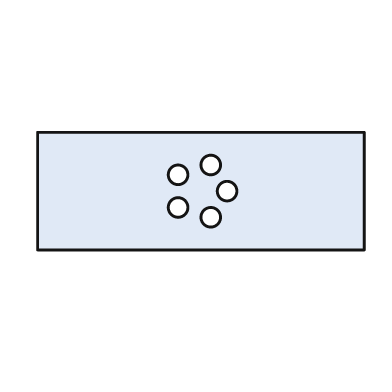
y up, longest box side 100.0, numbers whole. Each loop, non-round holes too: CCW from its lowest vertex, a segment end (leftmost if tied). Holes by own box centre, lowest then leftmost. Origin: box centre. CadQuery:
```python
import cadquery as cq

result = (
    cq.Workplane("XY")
    .moveTo(-50.0, -18.0)
    .lineTo(50.0, -18.0)
    .lineTo(50.0, 18.0)
    .lineTo(-50.0, 18.0)
    .close()
    .moveTo(3.0, -8.0)
    .circle(3.0)
    .moveTo(-7.0, -5.0)
    .circle(3.0)
    .moveTo(8.0, 0.0)
    .circle(3.0)
    .moveTo(-7.0, 5.0)
    .circle(3.0)
    .moveTo(3.0, 8.0)
    .circle(3.0)
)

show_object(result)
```